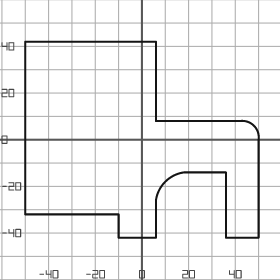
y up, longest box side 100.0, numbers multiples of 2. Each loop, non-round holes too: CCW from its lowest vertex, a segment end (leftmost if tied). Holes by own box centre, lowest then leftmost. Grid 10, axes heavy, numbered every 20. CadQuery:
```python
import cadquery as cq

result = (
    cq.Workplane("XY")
    .moveTo(-10.0, -42.0)
    .lineTo(6.0, -42.0)
    .lineTo(6.0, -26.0)
    .threePointArc((10.0, -18.0), (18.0, -14.0))
    .lineTo(36.0, -14.0)
    .lineTo(36.0, -42.0)
    .lineTo(50.0, -42.0)
    .lineTo(50.0, 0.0)
    .threePointArc((48.0, 6.0), (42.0, 8.0))
    .lineTo(6.0, 8.0)
    .lineTo(6.0, 42.0)
    .lineTo(-50.0, 42.0)
    .lineTo(-50.0, -32.0)
    .lineTo(-10.0, -32.0)
    .close()
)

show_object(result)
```